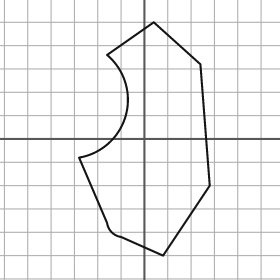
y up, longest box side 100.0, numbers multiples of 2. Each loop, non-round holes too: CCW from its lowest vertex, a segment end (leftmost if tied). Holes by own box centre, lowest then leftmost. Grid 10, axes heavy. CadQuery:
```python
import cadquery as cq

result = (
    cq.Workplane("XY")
    .moveTo(8.0, -50.0)
    .lineTo(28.0, -20.0)
    .lineTo(24.0, 32.0)
    .lineTo(4.0, 50.0)
    .lineTo(-16.0, 36.0)
    .threePointArc((-8.0, 10.0), (-28.0, -8.0))
    .lineTo(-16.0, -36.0)
    .threePointArc((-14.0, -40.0), (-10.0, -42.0))
    .close()
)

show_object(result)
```